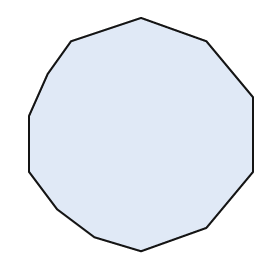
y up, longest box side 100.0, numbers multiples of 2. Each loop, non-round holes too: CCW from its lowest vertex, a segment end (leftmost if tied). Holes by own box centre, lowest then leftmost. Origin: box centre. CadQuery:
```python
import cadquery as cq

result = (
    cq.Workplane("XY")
    .moveTo(0.0, -50.0)
    .lineTo(28.0, -40.0)
    .lineTo(48.0, -16.0)
    .lineTo(48.0, 16.0)
    .lineTo(28.0, 40.0)
    .lineTo(0.0, 50.0)
    .lineTo(-30.0, 40.0)
    .lineTo(-40.0, 26.0)
    .lineTo(-48.0, 8.0)
    .lineTo(-48.0, -16.0)
    .lineTo(-36.0, -32.0)
    .lineTo(-20.0, -44.0)
    .close()
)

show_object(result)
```